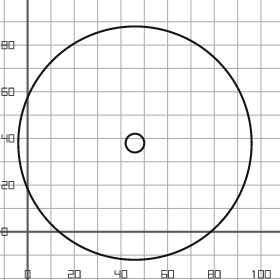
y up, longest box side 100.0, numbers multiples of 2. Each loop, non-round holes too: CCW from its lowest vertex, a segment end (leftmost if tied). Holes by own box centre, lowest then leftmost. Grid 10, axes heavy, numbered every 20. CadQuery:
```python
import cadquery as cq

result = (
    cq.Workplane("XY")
    .moveTo(46.0, 38.0)
    .circle(50.0)
    .moveTo(46.0, 38.0)
    .circle(4.0)
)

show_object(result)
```